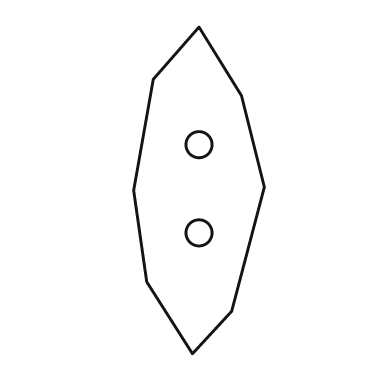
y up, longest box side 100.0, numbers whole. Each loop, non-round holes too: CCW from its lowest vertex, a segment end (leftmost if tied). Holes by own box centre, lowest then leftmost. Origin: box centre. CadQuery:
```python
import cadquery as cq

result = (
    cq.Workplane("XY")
    .moveTo(-2.0, -50.0)
    .lineTo(10.0, -37.0)
    .lineTo(20.0, 1.0)
    .lineTo(13.0, 29.0)
    .lineTo(0.0, 50.0)
    .lineTo(-14.0, 34.0)
    .lineTo(-20.0, 0.0)
    .lineTo(-16.0, -28.0)
    .close()
    .moveTo(0.0, -13.0)
    .circle(4.0)
    .moveTo(0.0, 14.0)
    .circle(4.0)
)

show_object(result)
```